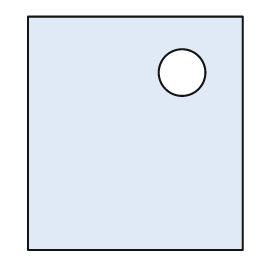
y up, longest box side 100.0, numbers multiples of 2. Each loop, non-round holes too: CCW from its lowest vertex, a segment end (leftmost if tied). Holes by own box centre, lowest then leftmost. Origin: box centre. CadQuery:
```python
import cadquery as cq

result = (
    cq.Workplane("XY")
    .moveTo(-46.0, -50.0)
    .lineTo(46.0, -50.0)
    .lineTo(46.0, 50.0)
    .lineTo(-46.0, 50.0)
    .close()
    .moveTo(20.0, 26.0)
    .circle(10.0)
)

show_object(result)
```